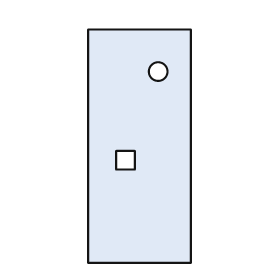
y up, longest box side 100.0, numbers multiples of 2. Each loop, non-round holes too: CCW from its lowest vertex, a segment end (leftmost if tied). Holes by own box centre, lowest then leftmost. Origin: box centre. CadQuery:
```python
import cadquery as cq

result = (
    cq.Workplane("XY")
    .moveTo(-22.0, -50.0)
    .lineTo(22.0, -50.0)
    .lineTo(22.0, 50.0)
    .lineTo(-22.0, 50.0)
    .close()
    .moveTo(-10.0, -10.0)
    .lineTo(-2.0, -10.0)
    .lineTo(-2.0, -2.0)
    .lineTo(-10.0, -2.0)
    .close()
    .moveTo(8.0, 32.0)
    .circle(4.0)
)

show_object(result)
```